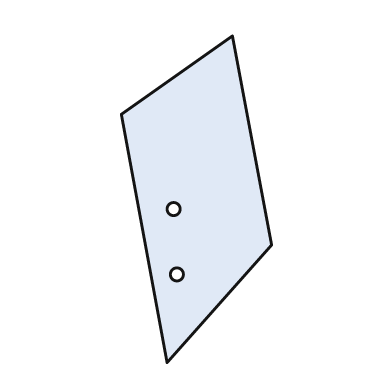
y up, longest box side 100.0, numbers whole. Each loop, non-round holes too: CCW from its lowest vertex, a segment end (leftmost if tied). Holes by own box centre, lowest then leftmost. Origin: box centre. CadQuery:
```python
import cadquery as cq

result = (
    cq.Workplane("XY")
    .moveTo(-9.0, -50.0)
    .lineTo(23.0, -14.0)
    .lineTo(11.0, 50.0)
    .lineTo(-23.0, 26.0)
    .close()
    .moveTo(-6.0, -23.0)
    .circle(2.0)
    .moveTo(-7.0, -3.0)
    .circle(2.0)
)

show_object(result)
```